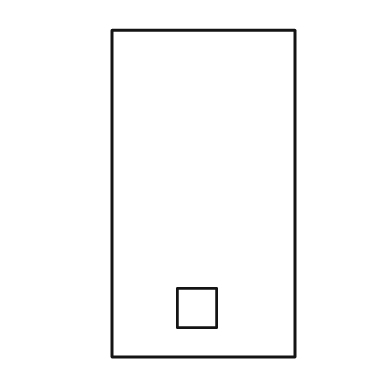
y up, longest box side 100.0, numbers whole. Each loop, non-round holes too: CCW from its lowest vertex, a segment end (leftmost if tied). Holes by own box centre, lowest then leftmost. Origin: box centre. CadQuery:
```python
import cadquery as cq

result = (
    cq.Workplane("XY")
    .moveTo(-28.0, -50.0)
    .lineTo(28.0, -50.0)
    .lineTo(28.0, 50.0)
    .lineTo(-28.0, 50.0)
    .close()
    .moveTo(-8.0, -41.0)
    .lineTo(4.0, -41.0)
    .lineTo(4.0, -29.0)
    .lineTo(-8.0, -29.0)
    .close()
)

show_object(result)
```